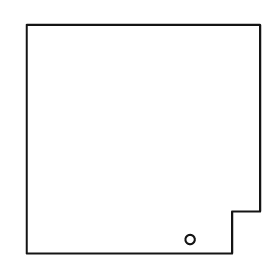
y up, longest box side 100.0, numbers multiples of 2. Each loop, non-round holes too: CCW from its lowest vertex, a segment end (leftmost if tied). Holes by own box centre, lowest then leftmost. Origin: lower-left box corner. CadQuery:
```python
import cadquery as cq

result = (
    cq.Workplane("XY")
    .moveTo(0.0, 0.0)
    .lineTo(88.0, 0.0)
    .lineTo(88.0, 18.0)
    .lineTo(100.0, 18.0)
    .lineTo(100.0, 98.0)
    .lineTo(0.0, 98.0)
    .close()
    .moveTo(70.0, 6.0)
    .circle(2.0)
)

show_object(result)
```